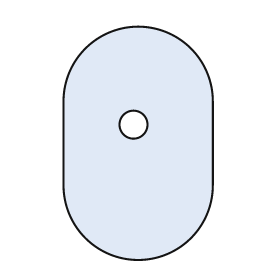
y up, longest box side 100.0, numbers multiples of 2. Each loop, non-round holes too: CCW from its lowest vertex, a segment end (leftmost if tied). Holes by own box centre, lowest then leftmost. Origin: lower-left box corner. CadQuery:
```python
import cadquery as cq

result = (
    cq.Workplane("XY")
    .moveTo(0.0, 32.0)
    .threePointArc((32.0, 0.0), (64.0, 32.0))
    .lineTo(64.0, 68.0)
    .threePointArc((32.0, 100.0), (0.0, 68.0))
    .close()
    .moveTo(30.0, 58.0)
    .circle(6.0)
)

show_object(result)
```